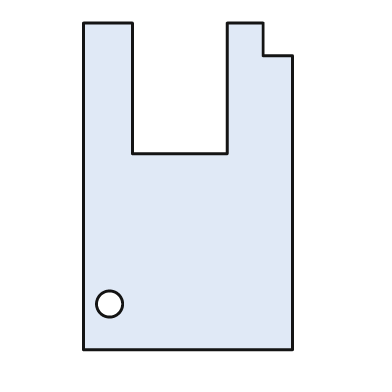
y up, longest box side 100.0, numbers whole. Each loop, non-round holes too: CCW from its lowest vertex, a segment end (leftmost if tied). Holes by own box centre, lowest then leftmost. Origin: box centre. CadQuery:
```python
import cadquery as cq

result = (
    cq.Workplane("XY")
    .moveTo(-32.0, -50.0)
    .lineTo(32.0, -50.0)
    .lineTo(32.0, 40.0)
    .lineTo(23.0, 40.0)
    .lineTo(23.0, 50.0)
    .lineTo(12.0, 50.0)
    .lineTo(12.0, 10.0)
    .lineTo(-17.0, 10.0)
    .lineTo(-17.0, 50.0)
    .lineTo(-32.0, 50.0)
    .close()
    .moveTo(-24.0, -36.0)
    .circle(4.0)
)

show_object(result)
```